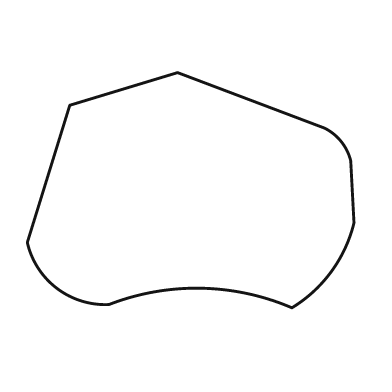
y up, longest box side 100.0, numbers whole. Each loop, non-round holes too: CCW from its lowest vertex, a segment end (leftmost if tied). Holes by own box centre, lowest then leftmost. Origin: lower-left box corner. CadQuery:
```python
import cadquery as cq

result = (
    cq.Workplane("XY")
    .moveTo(81.0, 0.0)
    .threePointArc((93.0, 11.0), (100.0, 26.0))
    .lineTo(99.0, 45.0)
    .threePointArc((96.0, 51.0), (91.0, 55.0))
    .lineTo(46.0, 72.0)
    .lineTo(13.0, 62.0)
    .lineTo(0.0, 20.0)
    .threePointArc((9.0, 6.0), (25.0, 1.0))
    .threePointArc((53.0, 6.0), (81.0, 0.0))
    .close()
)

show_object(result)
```